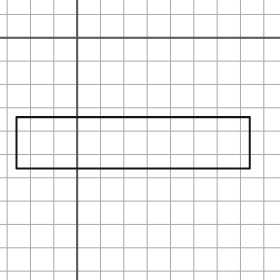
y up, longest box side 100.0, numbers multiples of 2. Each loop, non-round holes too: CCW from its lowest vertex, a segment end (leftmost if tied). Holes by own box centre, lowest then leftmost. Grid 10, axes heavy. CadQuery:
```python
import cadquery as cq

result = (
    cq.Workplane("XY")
    .moveTo(-26.0, -56.0)
    .lineTo(74.0, -56.0)
    .lineTo(74.0, -34.0)
    .lineTo(-26.0, -34.0)
    .close()
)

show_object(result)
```